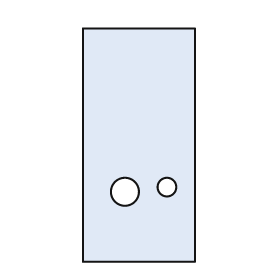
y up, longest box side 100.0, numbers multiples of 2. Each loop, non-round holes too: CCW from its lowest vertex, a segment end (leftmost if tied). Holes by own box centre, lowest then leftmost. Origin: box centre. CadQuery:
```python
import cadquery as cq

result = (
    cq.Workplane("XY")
    .moveTo(-24.0, -50.0)
    .lineTo(24.0, -50.0)
    .lineTo(24.0, 50.0)
    .lineTo(-24.0, 50.0)
    .close()
    .moveTo(-6.0, -20.0)
    .circle(6.0)
    .moveTo(12.0, -18.0)
    .circle(4.0)
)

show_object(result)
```